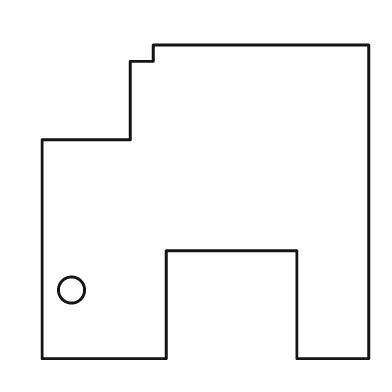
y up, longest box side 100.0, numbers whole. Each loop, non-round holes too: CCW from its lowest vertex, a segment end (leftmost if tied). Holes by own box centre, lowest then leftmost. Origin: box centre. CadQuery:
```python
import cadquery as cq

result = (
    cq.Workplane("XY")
    .moveTo(-50.0, -48.0)
    .lineTo(-12.0, -48.0)
    .lineTo(-12.0, -15.0)
    .lineTo(28.0, -15.0)
    .lineTo(28.0, -48.0)
    .lineTo(50.0, -48.0)
    .lineTo(50.0, 48.0)
    .lineTo(-16.0, 48.0)
    .lineTo(-16.0, 43.0)
    .lineTo(-23.0, 43.0)
    .lineTo(-23.0, 19.0)
    .lineTo(-50.0, 19.0)
    .close()
    .moveTo(-41.0, -27.0)
    .circle(4.0)
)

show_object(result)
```